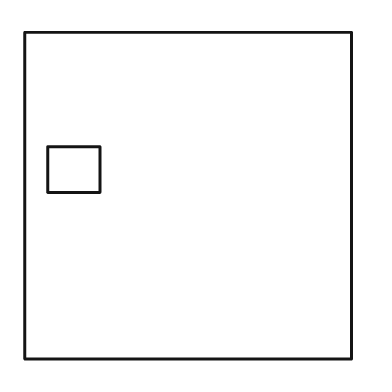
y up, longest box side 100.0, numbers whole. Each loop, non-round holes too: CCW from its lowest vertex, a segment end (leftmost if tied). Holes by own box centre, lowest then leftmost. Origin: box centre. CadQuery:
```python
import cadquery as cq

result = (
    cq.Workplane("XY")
    .moveTo(-50.0, -50.0)
    .lineTo(50.0, -50.0)
    .lineTo(50.0, 50.0)
    .lineTo(-50.0, 50.0)
    .close()
    .moveTo(-43.0, 1.0)
    .lineTo(-27.0, 1.0)
    .lineTo(-27.0, 15.0)
    .lineTo(-43.0, 15.0)
    .close()
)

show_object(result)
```